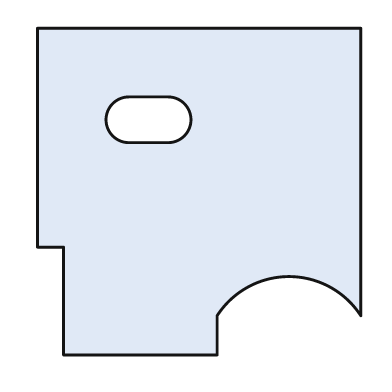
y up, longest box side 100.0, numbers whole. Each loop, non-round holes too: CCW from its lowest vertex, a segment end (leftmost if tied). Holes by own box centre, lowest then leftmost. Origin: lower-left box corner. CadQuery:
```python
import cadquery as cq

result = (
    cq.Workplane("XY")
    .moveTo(8.0, 0.0)
    .lineTo(55.0, 0.0)
    .lineTo(55.0, 12.0)
    .threePointArc((77.0, 24.0), (99.0, 12.0))
    .lineTo(99.0, 100.0)
    .lineTo(0.0, 100.0)
    .lineTo(0.0, 33.0)
    .lineTo(8.0, 33.0)
    .close()
    .moveTo(28.0, 65.0)
    .lineTo(40.0, 65.0)
    .threePointArc((47.0, 72.0), (40.0, 79.0))
    .lineTo(28.0, 79.0)
    .threePointArc((21.0, 72.0), (28.0, 65.0))
    .close()
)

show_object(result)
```